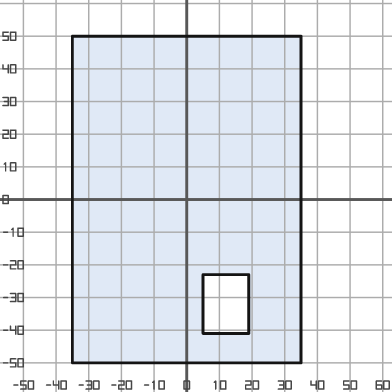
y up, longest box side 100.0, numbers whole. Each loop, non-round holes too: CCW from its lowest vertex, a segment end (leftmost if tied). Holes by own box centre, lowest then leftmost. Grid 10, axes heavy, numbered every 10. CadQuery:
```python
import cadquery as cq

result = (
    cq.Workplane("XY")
    .moveTo(-35.0, -50.0)
    .lineTo(35.0, -50.0)
    .lineTo(35.0, 50.0)
    .lineTo(-35.0, 50.0)
    .close()
    .moveTo(5.0, -41.0)
    .lineTo(19.0, -41.0)
    .lineTo(19.0, -23.0)
    .lineTo(5.0, -23.0)
    .close()
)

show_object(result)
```